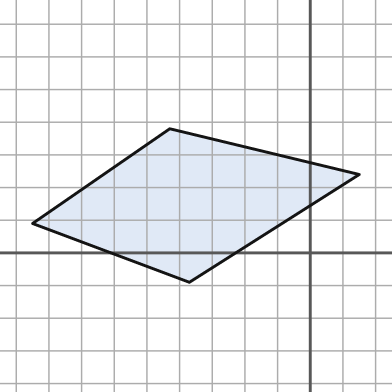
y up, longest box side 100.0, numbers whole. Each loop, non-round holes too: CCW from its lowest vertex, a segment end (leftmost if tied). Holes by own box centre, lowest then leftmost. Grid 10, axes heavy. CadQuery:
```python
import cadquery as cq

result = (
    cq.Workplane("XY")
    .moveTo(-37.0, -9.0)
    .lineTo(15.0, 24.0)
    .lineTo(-43.0, 38.0)
    .lineTo(-85.0, 9.0)
    .close()
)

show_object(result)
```